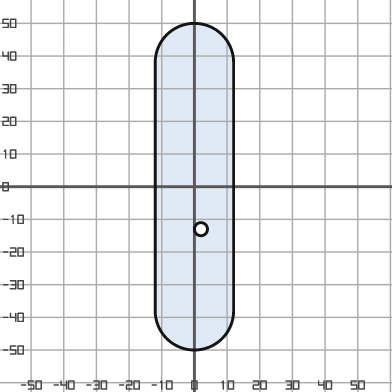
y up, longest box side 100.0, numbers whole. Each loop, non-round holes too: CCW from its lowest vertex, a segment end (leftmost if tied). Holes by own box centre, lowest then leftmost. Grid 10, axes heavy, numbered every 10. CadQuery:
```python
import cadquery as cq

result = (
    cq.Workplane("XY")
    .moveTo(-12.0, -38.0)
    .threePointArc((0.0, -50.0), (12.0, -38.0))
    .lineTo(12.0, 38.0)
    .threePointArc((0.0, 50.0), (-12.0, 38.0))
    .close()
    .moveTo(2.0, -13.0)
    .circle(2.0)
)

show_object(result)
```